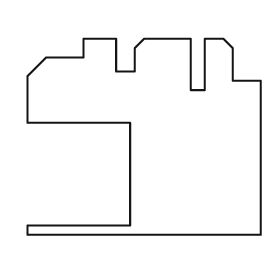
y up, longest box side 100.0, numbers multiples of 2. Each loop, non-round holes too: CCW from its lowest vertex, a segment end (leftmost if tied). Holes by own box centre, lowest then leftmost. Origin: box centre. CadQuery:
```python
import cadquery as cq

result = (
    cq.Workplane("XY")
    .moveTo(-50.0, -42.0)
    .lineTo(50.0, -42.0)
    .lineTo(50.0, 24.0)
    .lineTo(38.0, 24.0)
    .lineTo(38.0, 38.0)
    .lineTo(34.0, 42.0)
    .lineTo(26.0, 42.0)
    .lineTo(26.0, 20.0)
    .lineTo(20.0, 20.0)
    .lineTo(20.0, 42.0)
    .lineTo(0.0, 42.0)
    .lineTo(-4.0, 38.0)
    .lineTo(-4.0, 28.0)
    .lineTo(-12.0, 28.0)
    .lineTo(-12.0, 42.0)
    .lineTo(-26.0, 42.0)
    .lineTo(-26.0, 34.0)
    .lineTo(-42.0, 34.0)
    .lineTo(-50.0, 26.0)
    .lineTo(-50.0, 6.0)
    .lineTo(-6.0, 6.0)
    .lineTo(-6.0, -38.0)
    .lineTo(-50.0, -38.0)
    .close()
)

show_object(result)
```